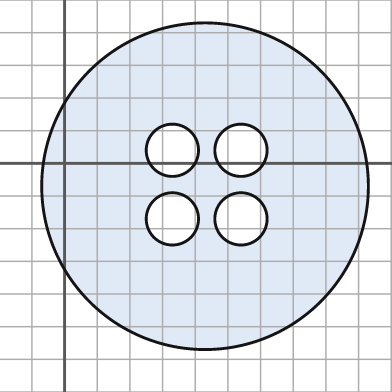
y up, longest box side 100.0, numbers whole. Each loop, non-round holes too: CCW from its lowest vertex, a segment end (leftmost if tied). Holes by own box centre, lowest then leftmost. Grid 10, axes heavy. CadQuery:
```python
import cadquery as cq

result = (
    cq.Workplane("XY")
    .moveTo(43.0, -7.0)
    .circle(50.0)
    .moveTo(33.0, -17.0)
    .circle(8.0)
    .moveTo(54.0, -17.0)
    .circle(8.0)
    .moveTo(33.0, 4.0)
    .circle(8.0)
    .moveTo(54.0, 4.0)
    .circle(8.0)
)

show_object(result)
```